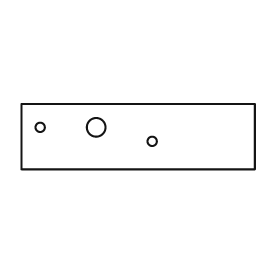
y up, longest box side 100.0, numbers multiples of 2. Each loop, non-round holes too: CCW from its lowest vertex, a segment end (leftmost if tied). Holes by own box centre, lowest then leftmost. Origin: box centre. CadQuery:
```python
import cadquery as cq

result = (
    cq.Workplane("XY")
    .moveTo(-50.0, -14.0)
    .lineTo(50.0, -14.0)
    .lineTo(50.0, 14.0)
    .lineTo(-50.0, 14.0)
    .close()
    .moveTo(6.0, -2.0)
    .circle(2.0)
    .moveTo(-42.0, 4.0)
    .circle(2.0)
    .moveTo(-18.0, 4.0)
    .circle(4.0)
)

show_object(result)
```